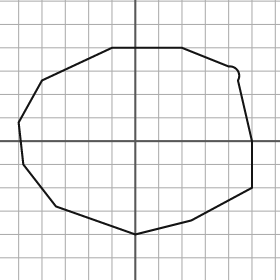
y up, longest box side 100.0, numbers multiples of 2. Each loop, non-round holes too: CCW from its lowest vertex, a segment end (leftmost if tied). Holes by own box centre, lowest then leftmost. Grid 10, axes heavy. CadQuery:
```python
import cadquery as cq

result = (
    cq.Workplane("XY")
    .moveTo(0.0, -40.0)
    .lineTo(24.0, -34.0)
    .lineTo(50.0, -20.0)
    .lineTo(50.0, 0.0)
    .lineTo(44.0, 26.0)
    .threePointArc((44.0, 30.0), (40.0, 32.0))
    .lineTo(20.0, 40.0)
    .lineTo(-10.0, 40.0)
    .lineTo(-40.0, 26.0)
    .lineTo(-50.0, 8.0)
    .lineTo(-48.0, -10.0)
    .lineTo(-34.0, -28.0)
    .close()
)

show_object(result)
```